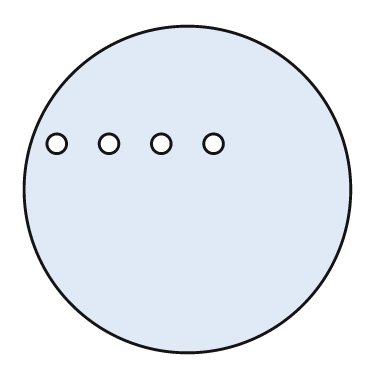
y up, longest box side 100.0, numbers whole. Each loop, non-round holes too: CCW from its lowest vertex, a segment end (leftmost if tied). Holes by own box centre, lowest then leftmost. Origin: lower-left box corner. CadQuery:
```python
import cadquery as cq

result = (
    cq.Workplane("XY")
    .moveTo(50.0, 50.0)
    .circle(50.0)
    .moveTo(10.0, 64.0)
    .circle(3.0)
    .moveTo(26.0, 64.0)
    .circle(3.0)
    .moveTo(42.0, 64.0)
    .circle(3.0)
    .moveTo(58.0, 64.0)
    .circle(3.0)
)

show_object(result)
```